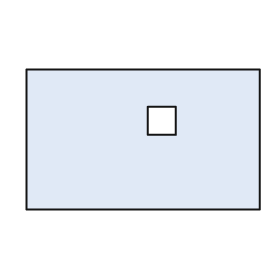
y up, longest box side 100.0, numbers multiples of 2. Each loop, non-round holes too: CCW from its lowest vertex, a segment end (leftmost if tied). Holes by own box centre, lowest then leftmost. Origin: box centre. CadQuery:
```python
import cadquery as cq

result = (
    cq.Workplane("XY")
    .moveTo(-50.0, -30.0)
    .lineTo(50.0, -30.0)
    .lineTo(50.0, 30.0)
    .lineTo(-50.0, 30.0)
    .close()
    .moveTo(2.0, 2.0)
    .lineTo(14.0, 2.0)
    .lineTo(14.0, 14.0)
    .lineTo(2.0, 14.0)
    .close()
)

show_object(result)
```